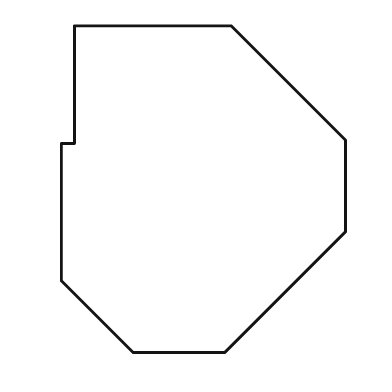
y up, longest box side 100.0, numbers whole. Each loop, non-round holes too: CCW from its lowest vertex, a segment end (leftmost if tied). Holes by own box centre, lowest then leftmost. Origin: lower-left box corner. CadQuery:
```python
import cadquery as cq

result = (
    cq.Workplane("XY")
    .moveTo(22.0, 0.0)
    .lineTo(50.0, 0.0)
    .lineTo(87.0, 37.0)
    .lineTo(87.0, 65.0)
    .lineTo(52.0, 100.0)
    .lineTo(4.0, 100.0)
    .lineTo(4.0, 64.0)
    .lineTo(0.0, 64.0)
    .lineTo(0.0, 22.0)
    .close()
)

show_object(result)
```